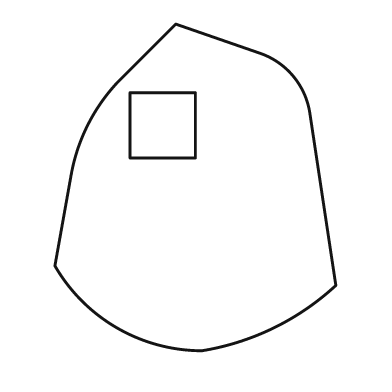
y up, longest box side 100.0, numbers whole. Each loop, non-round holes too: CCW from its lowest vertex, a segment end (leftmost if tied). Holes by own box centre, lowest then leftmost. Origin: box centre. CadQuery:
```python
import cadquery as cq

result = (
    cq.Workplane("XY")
    .moveTo(2.0, -50.0)
    .threePointArc((24.0, -43.0), (43.0, -30.0))
    .lineTo(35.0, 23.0)
    .threePointArc((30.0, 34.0), (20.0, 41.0))
    .lineTo(-6.0, 50.0)
    .lineTo(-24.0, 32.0)
    .threePointArc((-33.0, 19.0), (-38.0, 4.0))
    .lineTo(-43.0, -24.0)
    .threePointArc((-24.0, -43.0), (2.0, -50.0))
    .close()
    .moveTo(-20.0, 9.0)
    .lineTo(0.0, 9.0)
    .lineTo(0.0, 29.0)
    .lineTo(-20.0, 29.0)
    .close()
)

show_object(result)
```